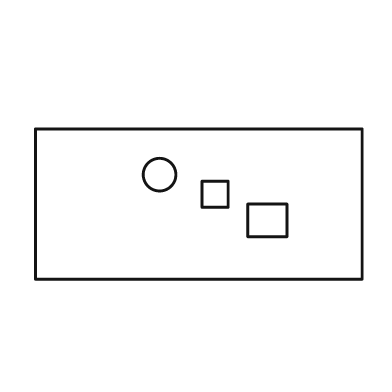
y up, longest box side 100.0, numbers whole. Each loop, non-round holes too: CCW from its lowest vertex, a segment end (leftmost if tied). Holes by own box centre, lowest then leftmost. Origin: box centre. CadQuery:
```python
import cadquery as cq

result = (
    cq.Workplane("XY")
    .moveTo(-50.0, -23.0)
    .lineTo(50.0, -23.0)
    .lineTo(50.0, 23.0)
    .lineTo(-50.0, 23.0)
    .close()
    .moveTo(15.0, -10.0)
    .lineTo(27.0, -10.0)
    .lineTo(27.0, 0.0)
    .lineTo(15.0, 0.0)
    .close()
    .moveTo(1.0, -1.0)
    .lineTo(9.0, -1.0)
    .lineTo(9.0, 7.0)
    .lineTo(1.0, 7.0)
    .close()
    .moveTo(-12.0, 9.0)
    .circle(5.0)
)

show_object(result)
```